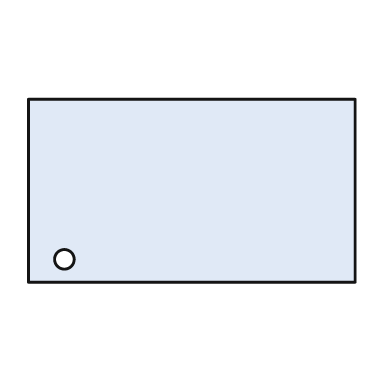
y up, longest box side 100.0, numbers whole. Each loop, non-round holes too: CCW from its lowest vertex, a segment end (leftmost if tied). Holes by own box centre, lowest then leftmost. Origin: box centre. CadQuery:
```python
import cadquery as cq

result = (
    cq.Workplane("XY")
    .moveTo(-50.0, -28.0)
    .lineTo(50.0, -28.0)
    .lineTo(50.0, 28.0)
    .lineTo(-50.0, 28.0)
    .close()
    .moveTo(-39.0, -21.0)
    .circle(3.0)
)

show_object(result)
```